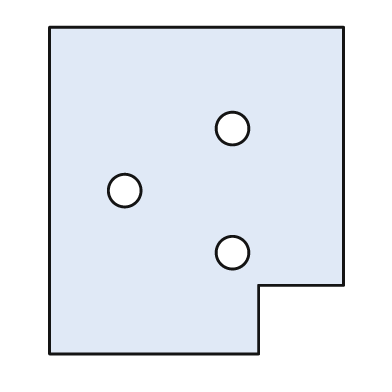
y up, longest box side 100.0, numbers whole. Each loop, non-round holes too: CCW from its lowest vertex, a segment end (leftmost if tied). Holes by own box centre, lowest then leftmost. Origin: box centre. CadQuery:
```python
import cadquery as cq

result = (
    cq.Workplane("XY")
    .moveTo(-45.0, -50.0)
    .lineTo(19.0, -50.0)
    .lineTo(19.0, -29.0)
    .lineTo(45.0, -29.0)
    .lineTo(45.0, 50.0)
    .lineTo(-45.0, 50.0)
    .close()
    .moveTo(11.0, -19.0)
    .circle(5.0)
    .moveTo(-22.0, 0.0)
    .circle(5.0)
    .moveTo(11.0, 19.0)
    .circle(5.0)
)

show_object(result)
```